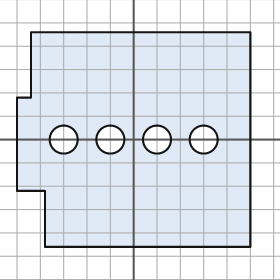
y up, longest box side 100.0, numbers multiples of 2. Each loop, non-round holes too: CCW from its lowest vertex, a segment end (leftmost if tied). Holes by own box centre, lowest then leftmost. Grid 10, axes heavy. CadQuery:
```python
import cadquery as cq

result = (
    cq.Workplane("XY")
    .moveTo(-38.0, -46.0)
    .lineTo(50.0, -46.0)
    .lineTo(50.0, 46.0)
    .lineTo(-44.0, 46.0)
    .lineTo(-44.0, 18.0)
    .lineTo(-50.0, 18.0)
    .lineTo(-50.0, -22.0)
    .lineTo(-38.0, -22.0)
    .close()
    .moveTo(-30.0, 0.0)
    .circle(6.0)
    .moveTo(-10.0, 0.0)
    .circle(6.0)
    .moveTo(10.0, 0.0)
    .circle(6.0)
    .moveTo(30.0, 0.0)
    .circle(6.0)
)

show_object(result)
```